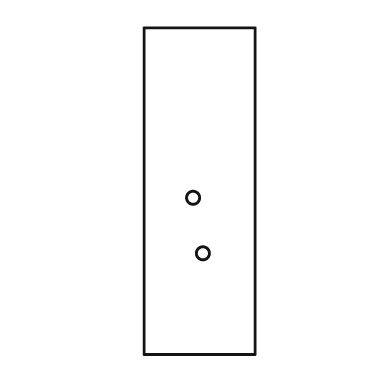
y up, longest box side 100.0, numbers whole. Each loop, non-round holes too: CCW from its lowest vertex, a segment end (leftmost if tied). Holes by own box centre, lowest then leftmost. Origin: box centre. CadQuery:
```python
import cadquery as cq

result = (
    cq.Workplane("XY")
    .moveTo(-17.0, -50.0)
    .lineTo(17.0, -50.0)
    .lineTo(17.0, 50.0)
    .lineTo(-17.0, 50.0)
    .close()
    .moveTo(1.0, -19.0)
    .circle(2.0)
    .moveTo(-2.0, -2.0)
    .circle(2.0)
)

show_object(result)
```